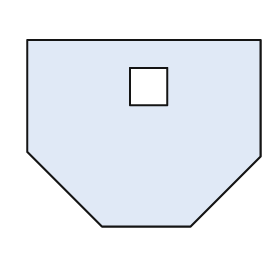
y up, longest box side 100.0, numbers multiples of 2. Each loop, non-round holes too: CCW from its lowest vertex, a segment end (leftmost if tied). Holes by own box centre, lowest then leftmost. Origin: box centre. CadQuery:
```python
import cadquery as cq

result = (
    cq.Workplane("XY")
    .moveTo(-18.0, -40.0)
    .lineTo(20.0, -40.0)
    .lineTo(50.0, -10.0)
    .lineTo(50.0, 40.0)
    .lineTo(-50.0, 40.0)
    .lineTo(-50.0, -8.0)
    .close()
    .moveTo(-6.0, 12.0)
    .lineTo(10.0, 12.0)
    .lineTo(10.0, 28.0)
    .lineTo(-6.0, 28.0)
    .close()
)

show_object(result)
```